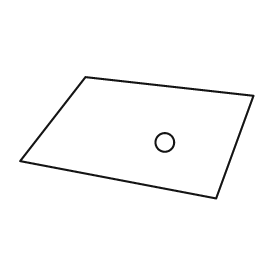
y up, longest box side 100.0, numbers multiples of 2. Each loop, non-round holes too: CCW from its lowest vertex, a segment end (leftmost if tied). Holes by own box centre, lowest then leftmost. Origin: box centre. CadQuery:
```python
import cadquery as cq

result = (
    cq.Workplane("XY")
    .moveTo(34.0, -26.0)
    .lineTo(50.0, 18.0)
    .lineTo(-22.0, 26.0)
    .lineTo(-50.0, -10.0)
    .close()
    .moveTo(12.0, -2.0)
    .circle(4.0)
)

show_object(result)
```